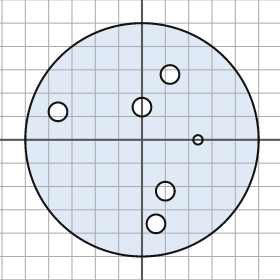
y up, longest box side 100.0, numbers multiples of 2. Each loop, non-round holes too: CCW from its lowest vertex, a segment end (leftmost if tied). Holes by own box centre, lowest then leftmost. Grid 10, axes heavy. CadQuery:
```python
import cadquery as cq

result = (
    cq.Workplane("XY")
    .moveTo(0.0, 0.0)
    .circle(50.0)
    .moveTo(6.0, -36.0)
    .circle(4.0)
    .moveTo(10.0, -22.0)
    .circle(4.0)
    .moveTo(24.0, 0.0)
    .circle(2.0)
    .moveTo(-36.0, 12.0)
    .circle(4.0)
    .moveTo(0.0, 14.0)
    .circle(4.0)
    .moveTo(12.0, 28.0)
    .circle(4.0)
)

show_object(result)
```